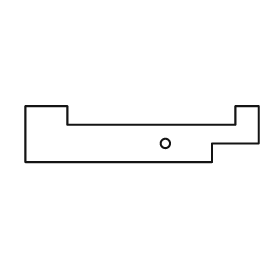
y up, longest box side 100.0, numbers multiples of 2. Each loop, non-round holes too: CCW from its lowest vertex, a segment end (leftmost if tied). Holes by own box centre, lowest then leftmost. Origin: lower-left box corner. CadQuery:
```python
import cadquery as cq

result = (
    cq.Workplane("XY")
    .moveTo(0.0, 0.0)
    .lineTo(80.0, 0.0)
    .lineTo(80.0, 8.0)
    .lineTo(100.0, 8.0)
    .lineTo(100.0, 24.0)
    .lineTo(90.0, 24.0)
    .lineTo(90.0, 16.0)
    .lineTo(18.0, 16.0)
    .lineTo(18.0, 24.0)
    .lineTo(0.0, 24.0)
    .close()
    .moveTo(60.0, 8.0)
    .circle(2.0)
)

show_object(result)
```